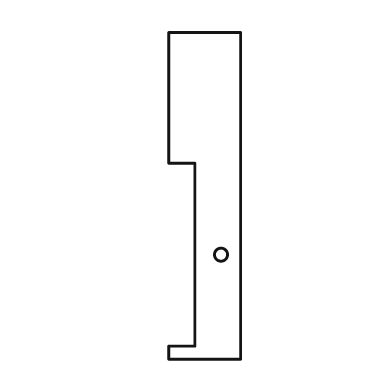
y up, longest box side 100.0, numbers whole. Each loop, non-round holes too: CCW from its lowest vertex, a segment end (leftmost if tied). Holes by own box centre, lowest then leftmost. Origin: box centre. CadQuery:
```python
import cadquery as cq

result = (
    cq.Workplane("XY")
    .moveTo(-11.0, -50.0)
    .lineTo(11.0, -50.0)
    .lineTo(11.0, 50.0)
    .lineTo(-11.0, 50.0)
    .lineTo(-11.0, 10.0)
    .lineTo(-3.0, 10.0)
    .lineTo(-3.0, -46.0)
    .lineTo(-11.0, -46.0)
    .close()
    .moveTo(5.0, -18.0)
    .circle(2.0)
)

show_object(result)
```